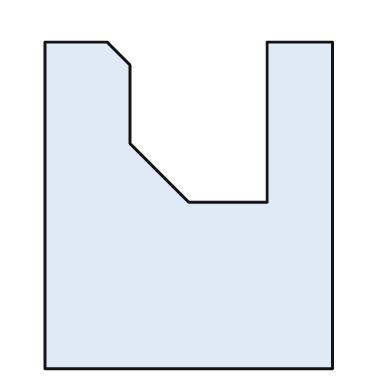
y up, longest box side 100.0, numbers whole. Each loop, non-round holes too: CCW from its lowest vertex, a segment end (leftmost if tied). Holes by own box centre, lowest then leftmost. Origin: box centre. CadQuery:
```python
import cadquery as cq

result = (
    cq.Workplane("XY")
    .moveTo(-44.0, -50.0)
    .lineTo(44.0, -50.0)
    .lineTo(44.0, 50.0)
    .lineTo(24.0, 50.0)
    .lineTo(24.0, 1.0)
    .lineTo(0.0, 1.0)
    .lineTo(-18.0, 19.0)
    .lineTo(-18.0, 43.0)
    .lineTo(-25.0, 50.0)
    .lineTo(-44.0, 50.0)
    .close()
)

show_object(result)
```